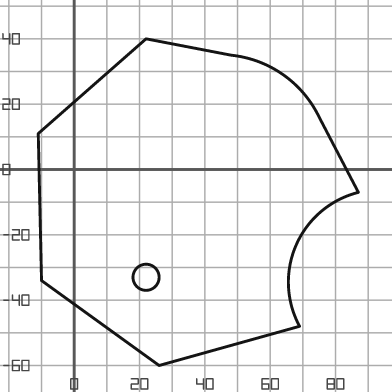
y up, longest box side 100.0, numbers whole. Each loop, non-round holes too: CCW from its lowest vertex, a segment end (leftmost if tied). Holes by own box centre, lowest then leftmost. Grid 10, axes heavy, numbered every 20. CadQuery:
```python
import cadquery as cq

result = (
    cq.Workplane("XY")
    .moveTo(26.0, -60.0)
    .lineTo(69.0, -48.0)
    .threePointArc((68.0, -23.0), (87.0, -7.0))
    .lineTo(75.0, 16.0)
    .threePointArc((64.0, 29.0), (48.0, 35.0))
    .lineTo(22.0, 40.0)
    .lineTo(-11.0, 11.0)
    .lineTo(-10.0, -34.0)
    .close()
    .moveTo(22.0, -33.0)
    .circle(4.0)
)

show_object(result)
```